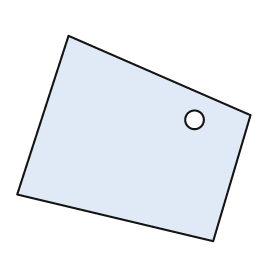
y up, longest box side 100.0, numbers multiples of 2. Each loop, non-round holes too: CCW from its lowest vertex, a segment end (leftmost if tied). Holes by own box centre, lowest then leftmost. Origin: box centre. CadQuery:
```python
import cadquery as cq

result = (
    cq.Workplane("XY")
    .moveTo(34.0, -44.0)
    .lineTo(50.0, 10.0)
    .lineTo(-28.0, 44.0)
    .lineTo(-50.0, -24.0)
    .close()
    .moveTo(26.0, 8.0)
    .circle(4.0)
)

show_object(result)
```